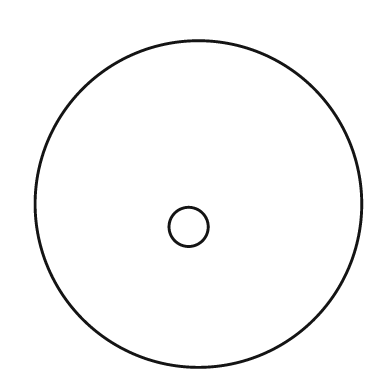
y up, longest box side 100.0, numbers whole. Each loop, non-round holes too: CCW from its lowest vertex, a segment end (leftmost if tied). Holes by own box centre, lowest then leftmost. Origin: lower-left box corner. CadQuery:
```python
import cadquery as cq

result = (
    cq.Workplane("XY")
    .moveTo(50.0, 50.0)
    .circle(50.0)
    .moveTo(47.0, 43.0)
    .circle(6.0)
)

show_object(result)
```